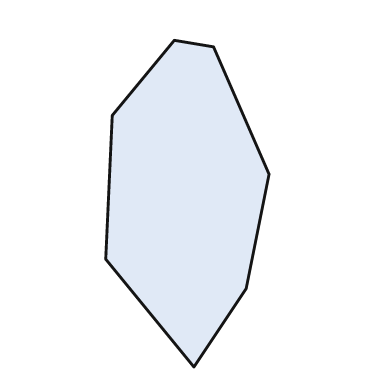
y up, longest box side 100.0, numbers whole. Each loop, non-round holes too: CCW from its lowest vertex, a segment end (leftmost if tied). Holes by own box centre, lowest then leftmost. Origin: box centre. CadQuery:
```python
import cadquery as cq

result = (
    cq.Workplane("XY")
    .moveTo(2.0, -50.0)
    .lineTo(18.0, -26.0)
    .lineTo(25.0, 9.0)
    .lineTo(8.0, 48.0)
    .lineTo(-4.0, 50.0)
    .lineTo(-23.0, 27.0)
    .lineTo(-25.0, -17.0)
    .close()
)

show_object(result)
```